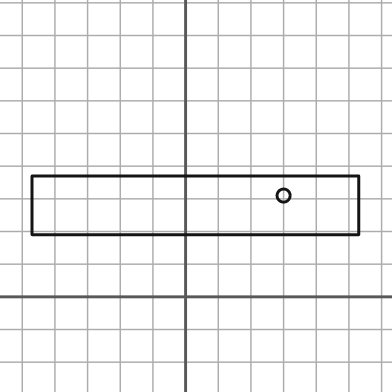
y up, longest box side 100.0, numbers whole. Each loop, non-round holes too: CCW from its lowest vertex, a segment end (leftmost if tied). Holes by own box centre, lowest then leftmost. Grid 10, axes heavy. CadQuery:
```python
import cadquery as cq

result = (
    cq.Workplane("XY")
    .moveTo(-47.0, 19.0)
    .lineTo(53.0, 19.0)
    .lineTo(53.0, 37.0)
    .lineTo(-47.0, 37.0)
    .close()
    .moveTo(30.0, 31.0)
    .circle(2.0)
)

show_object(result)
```